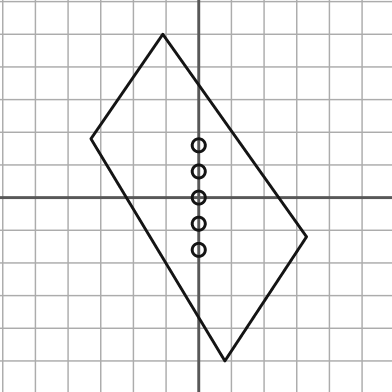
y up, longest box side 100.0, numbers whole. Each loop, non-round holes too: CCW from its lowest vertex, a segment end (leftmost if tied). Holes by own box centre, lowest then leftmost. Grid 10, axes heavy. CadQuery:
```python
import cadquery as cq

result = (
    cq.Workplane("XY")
    .moveTo(8.0, -50.0)
    .lineTo(33.0, -12.0)
    .lineTo(-11.0, 50.0)
    .lineTo(-33.0, 18.0)
    .close()
    .moveTo(0.0, -16.0)
    .circle(2.0)
    .moveTo(0.0, -8.0)
    .circle(2.0)
    .moveTo(0.0, 0.0)
    .circle(2.0)
    .moveTo(0.0, 8.0)
    .circle(2.0)
    .moveTo(0.0, 16.0)
    .circle(2.0)
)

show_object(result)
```